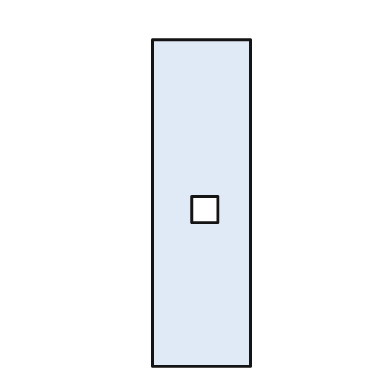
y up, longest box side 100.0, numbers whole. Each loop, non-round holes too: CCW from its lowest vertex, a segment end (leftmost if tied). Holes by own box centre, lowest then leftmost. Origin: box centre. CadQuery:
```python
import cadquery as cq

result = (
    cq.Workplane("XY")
    .moveTo(-15.0, -50.0)
    .lineTo(15.0, -50.0)
    .lineTo(15.0, 50.0)
    .lineTo(-15.0, 50.0)
    .close()
    .moveTo(-3.0, -6.0)
    .lineTo(5.0, -6.0)
    .lineTo(5.0, 2.0)
    .lineTo(-3.0, 2.0)
    .close()
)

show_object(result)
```